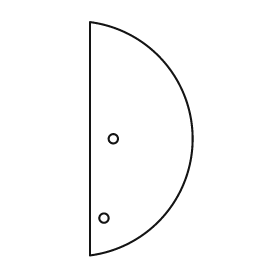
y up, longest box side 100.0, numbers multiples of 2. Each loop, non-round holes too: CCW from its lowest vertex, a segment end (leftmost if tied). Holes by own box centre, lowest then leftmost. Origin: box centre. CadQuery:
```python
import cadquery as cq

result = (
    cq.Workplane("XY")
    .moveTo(-22.0, -50.0)
    .threePointArc((22.0, 0.0), (-22.0, 50.0))
    .close()
    .moveTo(-16.0, -34.0)
    .circle(2.0)
    .moveTo(-12.0, 0.0)
    .circle(2.0)
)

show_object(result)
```